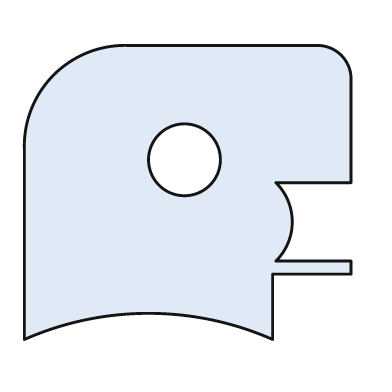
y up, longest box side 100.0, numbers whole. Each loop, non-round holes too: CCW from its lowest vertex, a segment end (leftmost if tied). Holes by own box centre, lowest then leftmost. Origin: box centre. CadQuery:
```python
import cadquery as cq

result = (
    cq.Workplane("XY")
    .moveTo(-50.0, -45.0)
    .threePointArc((-12.0, -37.0), (26.0, -45.0))
    .lineTo(26.0, -25.0)
    .lineTo(50.0, -25.0)
    .lineTo(50.0, -21.0)
    .lineTo(27.0, -21.0)
    .threePointArc((32.0, -9.0), (27.0, 3.0))
    .lineTo(50.0, 3.0)
    .lineTo(50.0, 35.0)
    .threePointArc((47.0, 42.0), (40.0, 45.0))
    .lineTo(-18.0, 45.0)
    .threePointArc((-41.0, 36.0), (-50.0, 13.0))
    .close()
    .moveTo(-1.0, 10.0)
    .circle(11.0)
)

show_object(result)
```